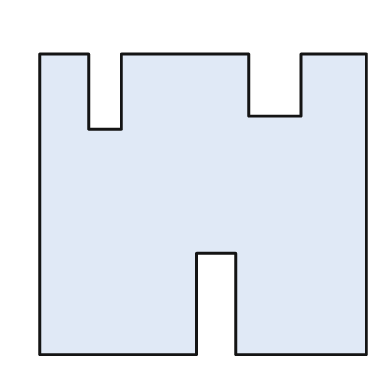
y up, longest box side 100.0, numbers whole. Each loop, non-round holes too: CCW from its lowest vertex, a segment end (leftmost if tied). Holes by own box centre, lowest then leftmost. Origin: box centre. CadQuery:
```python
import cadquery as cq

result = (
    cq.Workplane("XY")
    .moveTo(-50.0, -46.0)
    .lineTo(-2.0, -46.0)
    .lineTo(-2.0, -15.0)
    .lineTo(10.0, -15.0)
    .lineTo(10.0, -46.0)
    .lineTo(50.0, -46.0)
    .lineTo(50.0, 46.0)
    .lineTo(30.0, 46.0)
    .lineTo(30.0, 27.0)
    .lineTo(14.0, 27.0)
    .lineTo(14.0, 46.0)
    .lineTo(-25.0, 46.0)
    .lineTo(-25.0, 23.0)
    .lineTo(-35.0, 23.0)
    .lineTo(-35.0, 46.0)
    .lineTo(-50.0, 46.0)
    .close()
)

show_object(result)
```